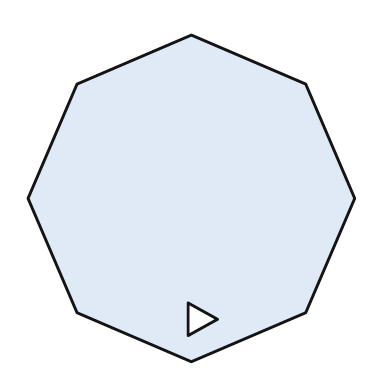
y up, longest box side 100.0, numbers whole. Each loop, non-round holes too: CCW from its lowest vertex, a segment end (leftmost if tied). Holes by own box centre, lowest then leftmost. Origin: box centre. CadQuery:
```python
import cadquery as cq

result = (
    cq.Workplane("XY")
    .moveTo(0.0, -50.0)
    .lineTo(35.0, -35.0)
    .lineTo(50.0, 0.0)
    .lineTo(35.0, 35.0)
    .lineTo(0.0, 50.0)
    .lineTo(-35.0, 35.0)
    .lineTo(-50.0, 0.0)
    .lineTo(-35.0, -35.0)
    .close()
    .moveTo(-1.0, -42.0)
    .lineTo(8.0, -37.0)
    .lineTo(-1.0, -32.0)
    .close()
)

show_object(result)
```